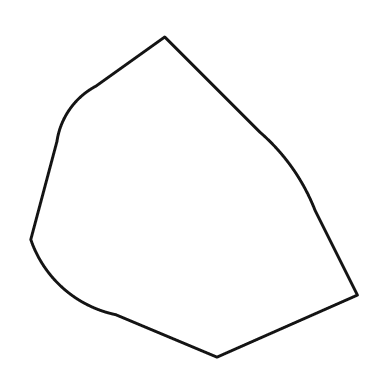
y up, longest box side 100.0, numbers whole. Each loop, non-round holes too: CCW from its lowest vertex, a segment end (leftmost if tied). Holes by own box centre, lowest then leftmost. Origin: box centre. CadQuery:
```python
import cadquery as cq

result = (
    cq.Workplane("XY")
    .moveTo(7.0, -49.0)
    .lineTo(50.0, -30.0)
    .lineTo(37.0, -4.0)
    .threePointArc((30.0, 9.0), (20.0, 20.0))
    .lineTo(-9.0, 49.0)
    .lineTo(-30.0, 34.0)
    .threePointArc((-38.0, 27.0), (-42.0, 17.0))
    .lineTo(-50.0, -13.0)
    .threePointArc((-40.0, -28.0), (-24.0, -36.0))
    .close()
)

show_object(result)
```